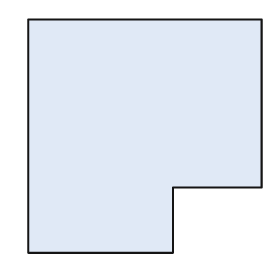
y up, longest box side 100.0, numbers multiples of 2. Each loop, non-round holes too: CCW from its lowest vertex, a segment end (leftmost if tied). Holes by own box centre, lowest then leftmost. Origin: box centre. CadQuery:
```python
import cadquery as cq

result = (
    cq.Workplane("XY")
    .moveTo(-50.0, -50.0)
    .lineTo(12.0, -50.0)
    .lineTo(12.0, -22.0)
    .lineTo(50.0, -22.0)
    .lineTo(50.0, 50.0)
    .lineTo(-50.0, 50.0)
    .close()
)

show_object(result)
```